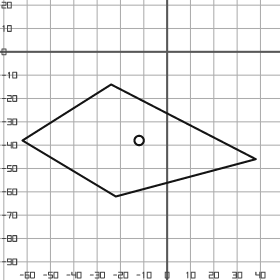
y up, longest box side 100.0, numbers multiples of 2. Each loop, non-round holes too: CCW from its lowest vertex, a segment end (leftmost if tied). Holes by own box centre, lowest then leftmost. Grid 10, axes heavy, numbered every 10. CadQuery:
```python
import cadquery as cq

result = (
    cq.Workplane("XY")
    .moveTo(-22.0, -62.0)
    .lineTo(38.0, -46.0)
    .lineTo(-24.0, -14.0)
    .lineTo(-62.0, -38.0)
    .close()
    .moveTo(-12.0, -38.0)
    .circle(2.0)
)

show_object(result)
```